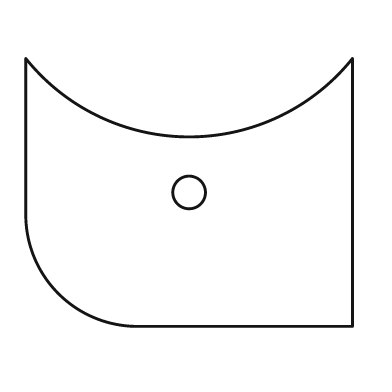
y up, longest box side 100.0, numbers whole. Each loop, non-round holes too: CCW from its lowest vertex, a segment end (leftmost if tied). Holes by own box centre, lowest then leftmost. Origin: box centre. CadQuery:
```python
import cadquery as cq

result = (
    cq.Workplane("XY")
    .moveTo(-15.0, -41.0)
    .lineTo(50.0, -41.0)
    .lineTo(50.0, 41.0)
    .threePointArc((0.0, 17.0), (-50.0, 41.0))
    .lineTo(-50.0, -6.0)
    .threePointArc((-40.0, -31.0), (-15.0, -41.0))
    .close()
    .moveTo(0.0, 0.0)
    .circle(5.0)
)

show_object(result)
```